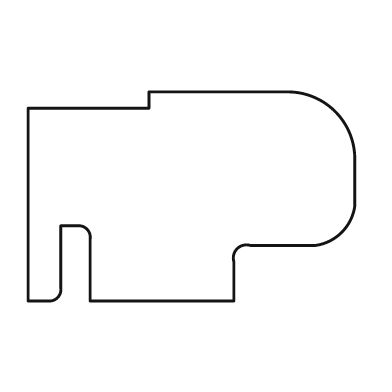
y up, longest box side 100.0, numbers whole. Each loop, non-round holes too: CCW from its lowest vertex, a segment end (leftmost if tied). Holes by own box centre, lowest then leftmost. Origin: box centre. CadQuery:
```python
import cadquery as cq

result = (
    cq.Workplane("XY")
    .moveTo(-50.0, -32.0)
    .lineTo(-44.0, -32.0)
    .threePointArc((-41.0, -31.0), (-40.0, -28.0))
    .lineTo(-40.0, -9.0)
    .lineTo(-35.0, -9.0)
    .threePointArc((-32.0, -10.0), (-31.0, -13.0))
    .lineTo(-31.0, -32.0)
    .lineTo(13.0, -32.0)
    .lineTo(13.0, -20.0)
    .threePointArc((14.0, -16.0), (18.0, -15.0))
    .lineTo(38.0, -15.0)
    .threePointArc((46.0, -11.0), (50.0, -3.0))
    .lineTo(50.0, 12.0)
    .threePointArc((44.0, 26.0), (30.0, 32.0))
    .lineTo(-13.0, 32.0)
    .lineTo(-13.0, 27.0)
    .lineTo(-50.0, 27.0)
    .close()
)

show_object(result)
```